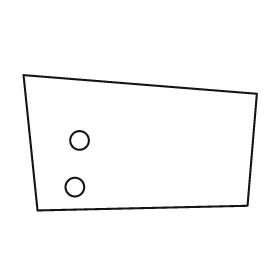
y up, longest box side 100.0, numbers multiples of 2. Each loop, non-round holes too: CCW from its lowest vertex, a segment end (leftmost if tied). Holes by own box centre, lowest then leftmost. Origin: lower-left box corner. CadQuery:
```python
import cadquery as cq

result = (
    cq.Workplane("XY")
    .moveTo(6.0, 0.0)
    .lineTo(96.0, 2.0)
    .lineTo(100.0, 50.0)
    .lineTo(0.0, 58.0)
    .close()
    .moveTo(22.0, 10.0)
    .circle(4.0)
    .moveTo(24.0, 30.0)
    .circle(4.0)
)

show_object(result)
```